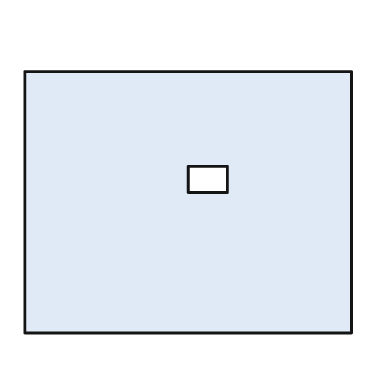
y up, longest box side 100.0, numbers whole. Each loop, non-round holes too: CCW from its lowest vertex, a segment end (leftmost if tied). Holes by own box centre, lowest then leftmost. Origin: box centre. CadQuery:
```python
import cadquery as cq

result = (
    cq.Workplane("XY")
    .moveTo(-50.0, -40.0)
    .lineTo(50.0, -40.0)
    .lineTo(50.0, 40.0)
    .lineTo(-50.0, 40.0)
    .close()
    .moveTo(0.0, 3.0)
    .lineTo(12.0, 3.0)
    .lineTo(12.0, 11.0)
    .lineTo(0.0, 11.0)
    .close()
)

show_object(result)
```